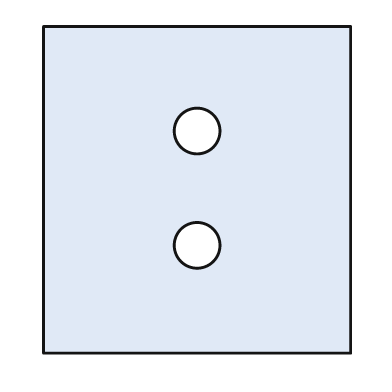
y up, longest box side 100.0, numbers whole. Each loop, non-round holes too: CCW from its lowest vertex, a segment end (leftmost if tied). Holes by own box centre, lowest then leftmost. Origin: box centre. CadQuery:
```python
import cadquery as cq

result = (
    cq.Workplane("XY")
    .moveTo(-47.0, -50.0)
    .lineTo(47.0, -50.0)
    .lineTo(47.0, 50.0)
    .lineTo(-47.0, 50.0)
    .close()
    .moveTo(0.0, -17.0)
    .circle(7.0)
    .moveTo(0.0, 18.0)
    .circle(7.0)
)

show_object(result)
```